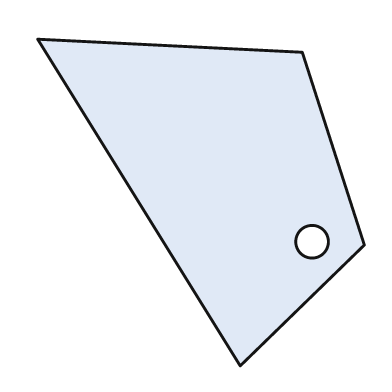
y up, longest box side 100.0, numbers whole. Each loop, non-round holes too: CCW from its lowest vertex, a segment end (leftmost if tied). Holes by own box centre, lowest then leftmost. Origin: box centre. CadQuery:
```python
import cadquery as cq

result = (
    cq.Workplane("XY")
    .moveTo(12.0, -50.0)
    .lineTo(50.0, -13.0)
    .lineTo(31.0, 46.0)
    .lineTo(-50.0, 50.0)
    .close()
    .moveTo(34.0, -12.0)
    .circle(5.0)
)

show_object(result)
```